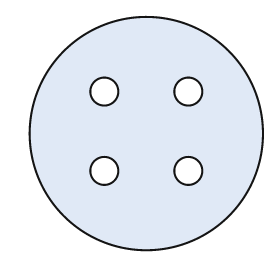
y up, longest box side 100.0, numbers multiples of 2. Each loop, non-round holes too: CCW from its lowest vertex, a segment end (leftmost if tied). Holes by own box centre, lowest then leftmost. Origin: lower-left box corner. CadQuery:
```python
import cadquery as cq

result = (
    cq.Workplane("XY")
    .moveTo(50.0, 50.0)
    .circle(50.0)
    .moveTo(32.0, 34.0)
    .circle(6.0)
    .moveTo(68.0, 34.0)
    .circle(6.0)
    .moveTo(32.0, 68.0)
    .circle(6.0)
    .moveTo(68.0, 68.0)
    .circle(6.0)
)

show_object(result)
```